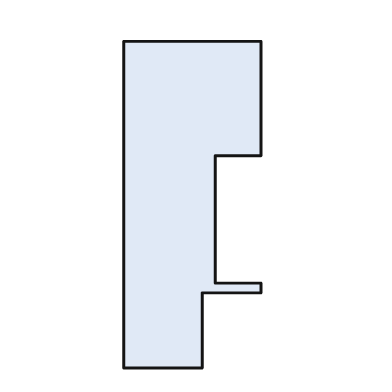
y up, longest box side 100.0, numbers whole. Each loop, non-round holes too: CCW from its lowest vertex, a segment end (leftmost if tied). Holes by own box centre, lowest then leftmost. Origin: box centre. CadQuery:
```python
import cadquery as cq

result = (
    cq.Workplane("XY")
    .moveTo(-21.0, -50.0)
    .lineTo(3.0, -50.0)
    .lineTo(3.0, -27.0)
    .lineTo(21.0, -27.0)
    .lineTo(21.0, -24.0)
    .lineTo(7.0, -24.0)
    .lineTo(7.0, 15.0)
    .lineTo(21.0, 15.0)
    .lineTo(21.0, 50.0)
    .lineTo(-21.0, 50.0)
    .close()
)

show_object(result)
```